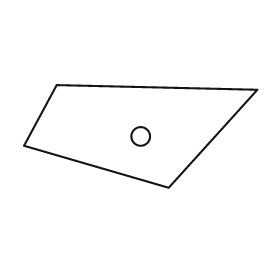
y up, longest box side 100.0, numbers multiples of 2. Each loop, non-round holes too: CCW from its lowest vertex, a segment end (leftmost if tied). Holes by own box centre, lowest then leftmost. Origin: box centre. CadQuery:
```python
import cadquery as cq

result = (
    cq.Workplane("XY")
    .moveTo(12.0, -22.0)
    .lineTo(50.0, 20.0)
    .lineTo(-36.0, 22.0)
    .lineTo(-50.0, -4.0)
    .close()
    .moveTo(0.0, 0.0)
    .circle(4.0)
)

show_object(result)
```